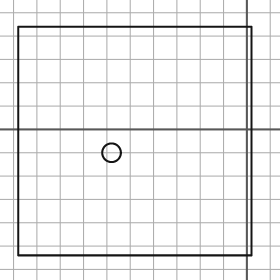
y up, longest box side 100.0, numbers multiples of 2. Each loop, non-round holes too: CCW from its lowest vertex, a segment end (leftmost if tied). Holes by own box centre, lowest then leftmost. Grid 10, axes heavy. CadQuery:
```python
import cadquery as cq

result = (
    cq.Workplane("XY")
    .moveTo(-98.0, -54.0)
    .lineTo(2.0, -54.0)
    .lineTo(2.0, 44.0)
    .lineTo(-98.0, 44.0)
    .close()
    .moveTo(-58.0, -10.0)
    .circle(4.0)
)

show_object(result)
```